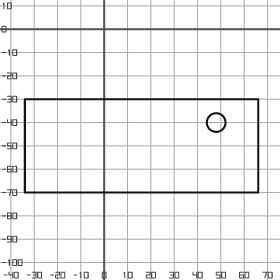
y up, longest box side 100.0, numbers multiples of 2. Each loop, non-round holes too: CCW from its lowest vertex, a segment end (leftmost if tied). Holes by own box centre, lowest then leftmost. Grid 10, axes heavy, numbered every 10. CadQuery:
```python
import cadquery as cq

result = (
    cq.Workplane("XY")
    .moveTo(-34.0, -70.0)
    .lineTo(66.0, -70.0)
    .lineTo(66.0, -30.0)
    .lineTo(-34.0, -30.0)
    .close()
    .moveTo(48.0, -40.0)
    .circle(4.0)
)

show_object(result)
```